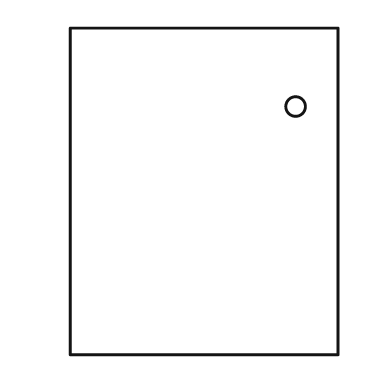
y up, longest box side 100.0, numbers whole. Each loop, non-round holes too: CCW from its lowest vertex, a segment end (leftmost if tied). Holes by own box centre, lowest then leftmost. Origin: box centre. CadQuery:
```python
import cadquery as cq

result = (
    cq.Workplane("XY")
    .moveTo(-41.0, -50.0)
    .lineTo(41.0, -50.0)
    .lineTo(41.0, 50.0)
    .lineTo(-41.0, 50.0)
    .close()
    .moveTo(28.0, 26.0)
    .circle(3.0)
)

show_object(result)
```